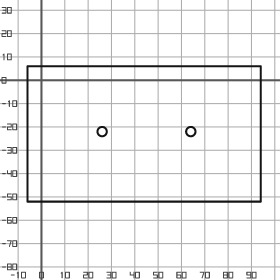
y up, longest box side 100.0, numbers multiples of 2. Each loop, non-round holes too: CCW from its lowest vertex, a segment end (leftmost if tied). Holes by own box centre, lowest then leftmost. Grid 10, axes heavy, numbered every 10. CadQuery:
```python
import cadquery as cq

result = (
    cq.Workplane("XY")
    .moveTo(-6.0, -52.0)
    .lineTo(94.0, -52.0)
    .lineTo(94.0, 6.0)
    .lineTo(-6.0, 6.0)
    .close()
    .moveTo(26.0, -22.0)
    .circle(2.0)
    .moveTo(64.0, -22.0)
    .circle(2.0)
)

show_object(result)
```